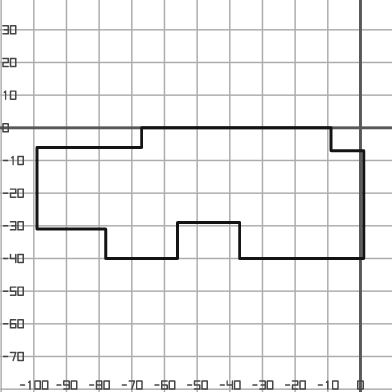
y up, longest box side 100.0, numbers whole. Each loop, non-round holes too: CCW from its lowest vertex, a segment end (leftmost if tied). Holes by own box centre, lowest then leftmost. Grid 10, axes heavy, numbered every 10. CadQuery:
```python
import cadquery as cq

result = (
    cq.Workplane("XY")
    .moveTo(-78.0, -40.0)
    .lineTo(-56.0, -40.0)
    .lineTo(-56.0, -29.0)
    .lineTo(-37.0, -29.0)
    .lineTo(-37.0, -40.0)
    .lineTo(1.0, -40.0)
    .lineTo(1.0, -7.0)
    .lineTo(-9.0, -7.0)
    .lineTo(-9.0, 0.0)
    .lineTo(-67.0, 0.0)
    .lineTo(-67.0, -6.0)
    .lineTo(-99.0, -6.0)
    .lineTo(-99.0, -31.0)
    .lineTo(-78.0, -31.0)
    .close()
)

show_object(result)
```